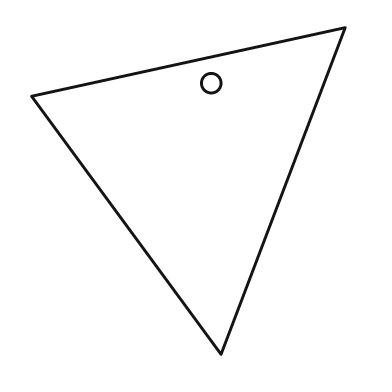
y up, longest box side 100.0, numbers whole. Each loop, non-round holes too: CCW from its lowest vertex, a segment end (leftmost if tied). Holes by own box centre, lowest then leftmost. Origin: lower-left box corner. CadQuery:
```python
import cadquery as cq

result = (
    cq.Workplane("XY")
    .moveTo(58.0, 0.0)
    .lineTo(96.0, 100.0)
    .lineTo(0.0, 79.0)
    .close()
    .moveTo(55.0, 83.0)
    .circle(3.0)
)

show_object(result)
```